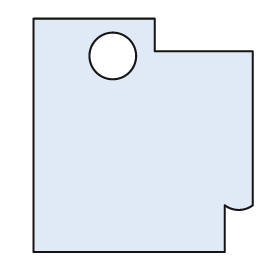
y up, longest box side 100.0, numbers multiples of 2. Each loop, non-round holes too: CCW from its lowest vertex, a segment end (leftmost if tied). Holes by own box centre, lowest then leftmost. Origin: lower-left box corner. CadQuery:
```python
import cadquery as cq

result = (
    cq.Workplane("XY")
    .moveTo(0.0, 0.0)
    .lineTo(82.0, 0.0)
    .lineTo(82.0, 20.0)
    .threePointArc((88.0, 18.0), (94.0, 20.0))
    .lineTo(94.0, 86.0)
    .lineTo(52.0, 86.0)
    .lineTo(52.0, 100.0)
    .lineTo(0.0, 100.0)
    .close()
    .moveTo(34.0, 84.0)
    .circle(10.0)
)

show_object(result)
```